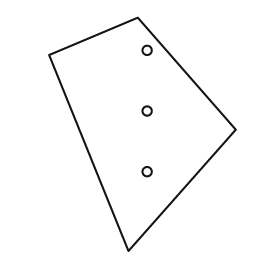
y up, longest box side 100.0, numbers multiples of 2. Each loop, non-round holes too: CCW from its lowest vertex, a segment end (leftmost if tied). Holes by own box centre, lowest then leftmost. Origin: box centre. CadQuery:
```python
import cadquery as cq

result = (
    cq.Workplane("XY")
    .moveTo(-6.0, -50.0)
    .lineTo(40.0, 2.0)
    .lineTo(-2.0, 50.0)
    .lineTo(-40.0, 34.0)
    .close()
    .moveTo(2.0, -16.0)
    .circle(2.0)
    .moveTo(2.0, 10.0)
    .circle(2.0)
    .moveTo(2.0, 36.0)
    .circle(2.0)
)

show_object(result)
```